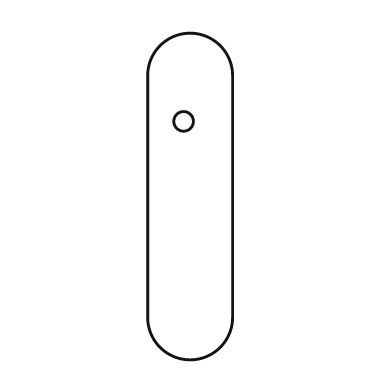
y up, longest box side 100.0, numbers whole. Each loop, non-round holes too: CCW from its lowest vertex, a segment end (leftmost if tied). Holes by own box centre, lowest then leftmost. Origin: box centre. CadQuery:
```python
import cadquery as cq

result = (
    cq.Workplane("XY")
    .moveTo(-13.0, -37.0)
    .threePointArc((0.0, -50.0), (13.0, -37.0))
    .lineTo(13.0, 37.0)
    .threePointArc((0.0, 50.0), (-13.0, 37.0))
    .close()
    .moveTo(-2.0, 23.0)
    .circle(3.0)
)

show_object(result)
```